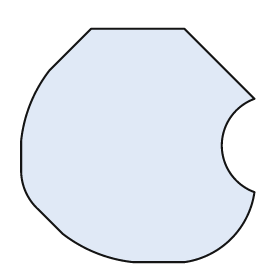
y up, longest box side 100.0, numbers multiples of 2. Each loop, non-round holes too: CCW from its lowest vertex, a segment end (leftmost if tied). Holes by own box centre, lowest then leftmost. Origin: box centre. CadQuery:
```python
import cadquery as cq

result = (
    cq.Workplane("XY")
    .moveTo(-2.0, -50.0)
    .lineTo(20.0, -50.0)
    .threePointArc((40.0, -40.0), (50.0, -20.0))
    .threePointArc((36.0, 0.0), (50.0, 20.0))
    .lineTo(20.0, 50.0)
    .lineTo(-20.0, 50.0)
    .lineTo(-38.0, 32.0)
    .threePointArc((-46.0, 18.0), (-50.0, 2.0))
    .lineTo(-50.0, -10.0)
    .threePointArc((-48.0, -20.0), (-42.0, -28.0))
    .lineTo(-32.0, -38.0)
    .threePointArc((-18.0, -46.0), (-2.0, -50.0))
    .close()
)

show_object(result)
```